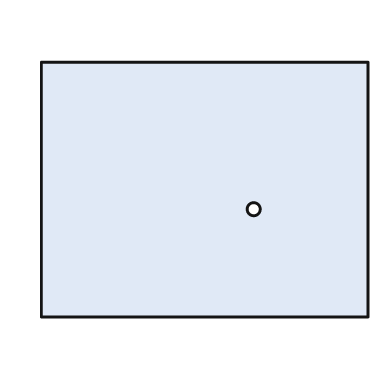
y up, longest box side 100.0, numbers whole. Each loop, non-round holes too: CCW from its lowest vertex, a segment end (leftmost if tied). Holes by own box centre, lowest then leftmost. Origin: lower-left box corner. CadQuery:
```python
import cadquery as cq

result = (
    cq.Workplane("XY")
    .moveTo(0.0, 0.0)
    .lineTo(100.0, 0.0)
    .lineTo(100.0, 78.0)
    .lineTo(0.0, 78.0)
    .close()
    .moveTo(65.0, 33.0)
    .circle(2.0)
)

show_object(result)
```